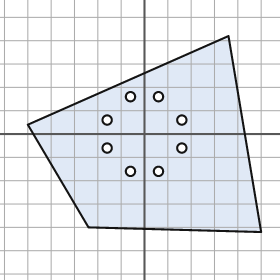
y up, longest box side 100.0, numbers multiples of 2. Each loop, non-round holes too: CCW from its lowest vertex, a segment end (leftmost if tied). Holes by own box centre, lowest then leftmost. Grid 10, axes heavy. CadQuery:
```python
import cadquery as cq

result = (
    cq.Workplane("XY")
    .moveTo(50.0, -42.0)
    .lineTo(36.0, 42.0)
    .lineTo(-50.0, 4.0)
    .lineTo(-24.0, -40.0)
    .close()
    .moveTo(-6.0, -16.0)
    .circle(2.0)
    .moveTo(6.0, -16.0)
    .circle(2.0)
    .moveTo(-16.0, -6.0)
    .circle(2.0)
    .moveTo(16.0, -6.0)
    .circle(2.0)
    .moveTo(-16.0, 6.0)
    .circle(2.0)
    .moveTo(16.0, 6.0)
    .circle(2.0)
    .moveTo(-6.0, 16.0)
    .circle(2.0)
    .moveTo(6.0, 16.0)
    .circle(2.0)
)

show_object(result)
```